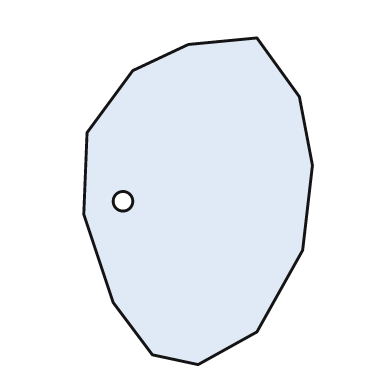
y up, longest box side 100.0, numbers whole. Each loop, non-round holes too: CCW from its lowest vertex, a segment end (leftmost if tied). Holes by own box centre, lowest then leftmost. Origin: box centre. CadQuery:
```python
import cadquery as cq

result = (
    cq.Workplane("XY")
    .moveTo(0.0, -50.0)
    .lineTo(18.0, -40.0)
    .lineTo(32.0, -15.0)
    .lineTo(35.0, 11.0)
    .lineTo(31.0, 32.0)
    .lineTo(18.0, 50.0)
    .lineTo(-3.0, 48.0)
    .lineTo(-20.0, 40.0)
    .lineTo(-34.0, 21.0)
    .lineTo(-35.0, -4.0)
    .lineTo(-26.0, -31.0)
    .lineTo(-14.0, -47.0)
    .close()
    .moveTo(-23.0, 0.0)
    .circle(3.0)
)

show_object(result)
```